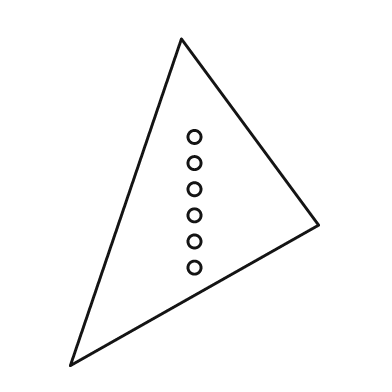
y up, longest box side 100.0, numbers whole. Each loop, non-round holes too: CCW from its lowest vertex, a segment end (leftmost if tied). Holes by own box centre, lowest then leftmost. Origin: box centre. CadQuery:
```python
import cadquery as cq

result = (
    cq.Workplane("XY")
    .moveTo(-38.0, -50.0)
    .lineTo(38.0, -7.0)
    .lineTo(-4.0, 50.0)
    .close()
    .moveTo(0.0, -20.0)
    .circle(2.0)
    .moveTo(0.0, -12.0)
    .circle(2.0)
    .moveTo(0.0, -4.0)
    .circle(2.0)
    .moveTo(0.0, 4.0)
    .circle(2.0)
    .moveTo(0.0, 12.0)
    .circle(2.0)
    .moveTo(0.0, 20.0)
    .circle(2.0)
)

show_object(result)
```